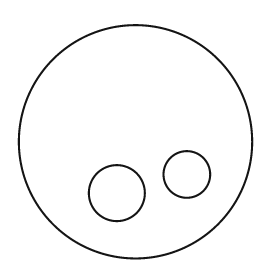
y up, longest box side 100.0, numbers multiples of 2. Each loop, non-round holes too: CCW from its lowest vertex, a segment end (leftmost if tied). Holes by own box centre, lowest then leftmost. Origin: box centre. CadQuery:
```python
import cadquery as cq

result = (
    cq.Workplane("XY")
    .moveTo(0.0, 0.0)
    .circle(50.0)
    .moveTo(-8.0, -22.0)
    .circle(12.0)
    .moveTo(22.0, -14.0)
    .circle(10.0)
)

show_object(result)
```